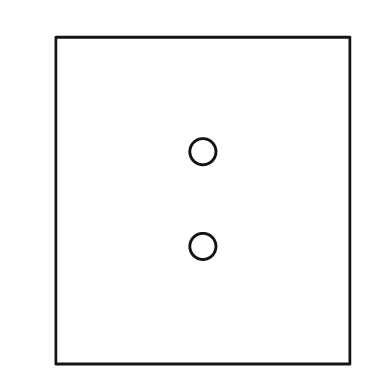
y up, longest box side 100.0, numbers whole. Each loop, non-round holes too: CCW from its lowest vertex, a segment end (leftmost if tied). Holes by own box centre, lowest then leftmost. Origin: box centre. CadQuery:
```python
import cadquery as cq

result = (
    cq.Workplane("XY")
    .moveTo(-45.0, -50.0)
    .lineTo(45.0, -50.0)
    .lineTo(45.0, 50.0)
    .lineTo(-45.0, 50.0)
    .close()
    .moveTo(0.0, -14.0)
    .circle(4.0)
    .moveTo(0.0, 15.0)
    .circle(4.0)
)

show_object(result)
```